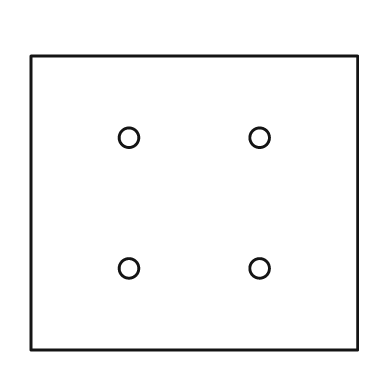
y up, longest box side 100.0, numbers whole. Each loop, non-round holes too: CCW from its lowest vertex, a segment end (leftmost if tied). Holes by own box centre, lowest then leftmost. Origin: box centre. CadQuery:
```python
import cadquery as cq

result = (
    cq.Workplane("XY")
    .moveTo(-50.0, -45.0)
    .lineTo(50.0, -45.0)
    .lineTo(50.0, 45.0)
    .lineTo(-50.0, 45.0)
    .close()
    .moveTo(-20.0, -20.0)
    .circle(3.0)
    .moveTo(20.0, -20.0)
    .circle(3.0)
    .moveTo(-20.0, 20.0)
    .circle(3.0)
    .moveTo(20.0, 20.0)
    .circle(3.0)
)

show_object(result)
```